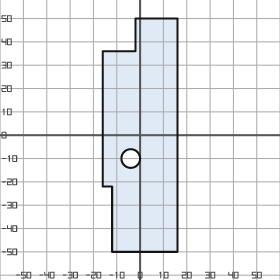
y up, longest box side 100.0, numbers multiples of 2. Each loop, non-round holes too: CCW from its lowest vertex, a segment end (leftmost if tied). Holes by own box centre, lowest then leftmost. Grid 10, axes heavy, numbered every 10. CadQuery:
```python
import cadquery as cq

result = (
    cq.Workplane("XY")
    .moveTo(-12.0, -50.0)
    .lineTo(16.0, -50.0)
    .lineTo(16.0, 50.0)
    .lineTo(-2.0, 50.0)
    .lineTo(-2.0, 36.0)
    .lineTo(-16.0, 36.0)
    .lineTo(-16.0, -22.0)
    .lineTo(-12.0, -22.0)
    .close()
    .moveTo(-4.0, -10.0)
    .circle(4.0)
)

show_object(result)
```